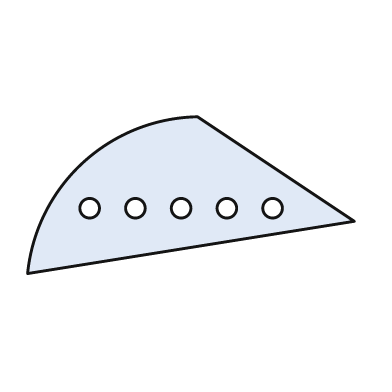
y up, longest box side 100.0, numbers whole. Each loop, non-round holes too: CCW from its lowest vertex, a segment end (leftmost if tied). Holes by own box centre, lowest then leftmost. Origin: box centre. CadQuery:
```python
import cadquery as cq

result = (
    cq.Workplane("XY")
    .moveTo(-50.0, -24.0)
    .lineTo(50.0, -8.0)
    .lineTo(2.0, 24.0)
    .threePointArc((-33.0, 10.0), (-50.0, -24.0))
    .close()
    .moveTo(-31.0, -4.0)
    .circle(3.0)
    .moveTo(-17.0, -4.0)
    .circle(3.0)
    .moveTo(-3.0, -4.0)
    .circle(3.0)
    .moveTo(11.0, -4.0)
    .circle(3.0)
    .moveTo(25.0, -4.0)
    .circle(3.0)
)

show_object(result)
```